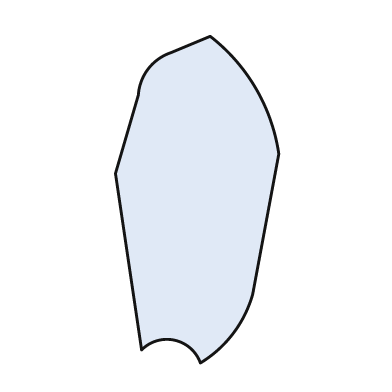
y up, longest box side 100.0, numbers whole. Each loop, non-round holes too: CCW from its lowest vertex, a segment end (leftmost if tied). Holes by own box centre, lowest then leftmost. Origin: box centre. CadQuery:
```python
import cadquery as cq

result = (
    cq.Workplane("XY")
    .moveTo(1.0, -50.0)
    .threePointArc((11.0, -41.0), (17.0, -29.0))
    .lineTo(25.0, 14.0)
    .threePointArc((18.0, 34.0), (4.0, 50.0))
    .lineTo(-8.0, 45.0)
    .threePointArc((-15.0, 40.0), (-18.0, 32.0))
    .lineTo(-25.0, 8.0)
    .lineTo(-17.0, -46.0)
    .threePointArc((-7.0, -43.0), (1.0, -50.0))
    .close()
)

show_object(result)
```